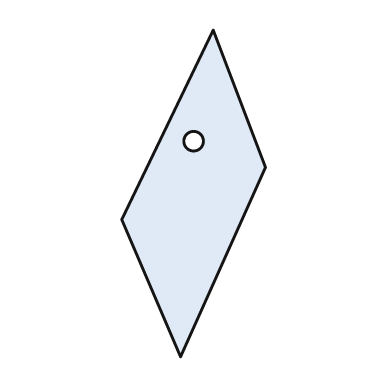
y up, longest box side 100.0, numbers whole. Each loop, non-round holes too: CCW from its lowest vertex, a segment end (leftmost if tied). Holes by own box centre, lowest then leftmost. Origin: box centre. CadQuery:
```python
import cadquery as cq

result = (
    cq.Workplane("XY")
    .moveTo(-4.0, -50.0)
    .lineTo(22.0, 8.0)
    .lineTo(6.0, 50.0)
    .lineTo(-22.0, -8.0)
    .close()
    .moveTo(0.0, 16.0)
    .circle(3.0)
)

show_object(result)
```